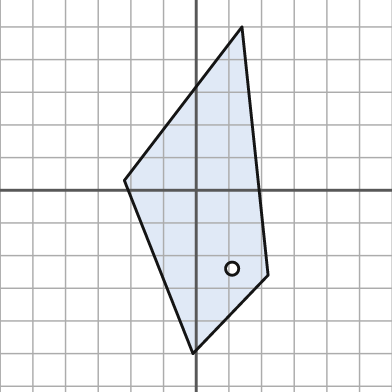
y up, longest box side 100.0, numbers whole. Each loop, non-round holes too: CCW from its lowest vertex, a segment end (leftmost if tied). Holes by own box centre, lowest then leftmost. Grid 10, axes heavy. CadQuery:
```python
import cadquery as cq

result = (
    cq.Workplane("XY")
    .moveTo(-1.0, -50.0)
    .lineTo(22.0, -26.0)
    .lineTo(14.0, 50.0)
    .lineTo(-22.0, 3.0)
    .close()
    .moveTo(11.0, -24.0)
    .circle(2.0)
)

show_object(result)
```